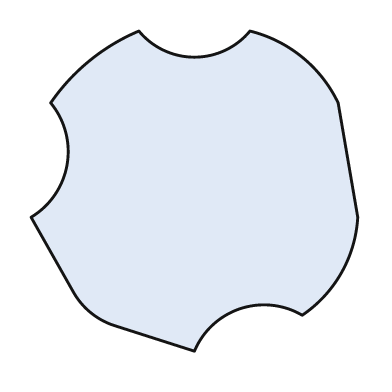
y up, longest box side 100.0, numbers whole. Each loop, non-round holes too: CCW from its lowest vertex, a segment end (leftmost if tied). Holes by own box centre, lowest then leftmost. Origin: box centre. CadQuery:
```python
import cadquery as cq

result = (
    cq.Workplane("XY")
    .moveTo(0.0, -49.0)
    .threePointArc((14.0, -36.0), (33.0, -38.0))
    .threePointArc((45.0, -25.0), (50.0, -8.0))
    .lineTo(44.0, 27.0)
    .threePointArc((33.0, 41.0), (17.0, 49.0))
    .threePointArc((0.0, 41.0), (-17.0, 49.0))
    .threePointArc((-32.0, 40.0), (-44.0, 27.0))
    .threePointArc((-39.0, 8.0), (-50.0, -8.0))
    .lineTo(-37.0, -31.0)
    .threePointArc((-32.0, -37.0), (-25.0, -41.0))
    .close()
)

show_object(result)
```